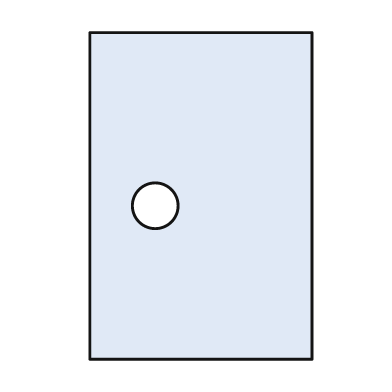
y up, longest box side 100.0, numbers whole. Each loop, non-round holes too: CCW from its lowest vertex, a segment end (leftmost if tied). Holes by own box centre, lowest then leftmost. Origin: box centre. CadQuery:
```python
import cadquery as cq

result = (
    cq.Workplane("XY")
    .moveTo(-34.0, -50.0)
    .lineTo(34.0, -50.0)
    .lineTo(34.0, 50.0)
    .lineTo(-34.0, 50.0)
    .close()
    .moveTo(-14.0, -3.0)
    .circle(7.0)
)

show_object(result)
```